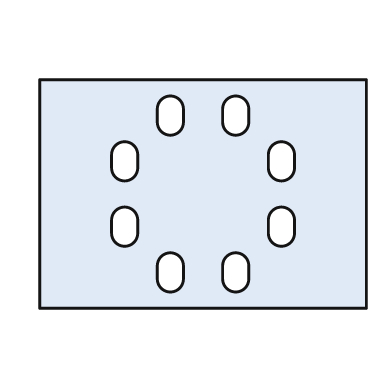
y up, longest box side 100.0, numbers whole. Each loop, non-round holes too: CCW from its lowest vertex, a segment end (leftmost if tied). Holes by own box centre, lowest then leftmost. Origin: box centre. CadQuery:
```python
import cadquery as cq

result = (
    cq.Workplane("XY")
    .moveTo(-50.0, -35.0)
    .lineTo(50.0, -35.0)
    .lineTo(50.0, 35.0)
    .lineTo(-50.0, 35.0)
    .close()
    .moveTo(-14.0, -26.0)
    .threePointArc((-10.0, -30.0), (-6.0, -26.0))
    .lineTo(-6.0, -22.0)
    .threePointArc((-10.0, -18.0), (-14.0, -22.0))
    .close()
    .moveTo(6.0, -26.0)
    .threePointArc((10.0, -30.0), (14.0, -26.0))
    .lineTo(14.0, -22.0)
    .threePointArc((10.0, -18.0), (6.0, -22.0))
    .close()
    .moveTo(-28.0, -12.0)
    .threePointArc((-24.0, -16.0), (-20.0, -12.0))
    .lineTo(-20.0, -8.0)
    .threePointArc((-24.0, -4.0), (-28.0, -8.0))
    .close()
    .moveTo(20.0, -12.0)
    .threePointArc((24.0, -16.0), (28.0, -12.0))
    .lineTo(28.0, -8.0)
    .threePointArc((24.0, -4.0), (20.0, -8.0))
    .close()
    .moveTo(-28.0, 8.0)
    .threePointArc((-24.0, 4.0), (-20.0, 8.0))
    .lineTo(-20.0, 12.0)
    .threePointArc((-24.0, 16.0), (-28.0, 12.0))
    .close()
    .moveTo(20.0, 8.0)
    .threePointArc((24.0, 4.0), (28.0, 8.0))
    .lineTo(28.0, 12.0)
    .threePointArc((24.0, 16.0), (20.0, 12.0))
    .close()
    .moveTo(-14.0, 22.0)
    .threePointArc((-10.0, 18.0), (-6.0, 22.0))
    .lineTo(-6.0, 26.0)
    .threePointArc((-10.0, 30.0), (-14.0, 26.0))
    .close()
    .moveTo(6.0, 22.0)
    .threePointArc((10.0, 18.0), (14.0, 22.0))
    .lineTo(14.0, 26.0)
    .threePointArc((10.0, 30.0), (6.0, 26.0))
    .close()
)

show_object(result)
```